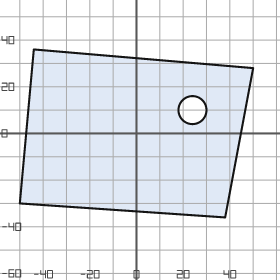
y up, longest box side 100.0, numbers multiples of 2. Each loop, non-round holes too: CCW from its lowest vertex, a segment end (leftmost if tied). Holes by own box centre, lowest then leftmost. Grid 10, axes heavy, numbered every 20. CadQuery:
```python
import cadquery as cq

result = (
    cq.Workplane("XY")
    .moveTo(38.0, -36.0)
    .lineTo(50.0, 28.0)
    .lineTo(-44.0, 36.0)
    .lineTo(-50.0, -30.0)
    .close()
    .moveTo(24.0, 10.0)
    .circle(6.0)
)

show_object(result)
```